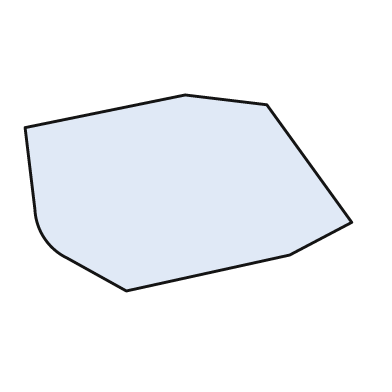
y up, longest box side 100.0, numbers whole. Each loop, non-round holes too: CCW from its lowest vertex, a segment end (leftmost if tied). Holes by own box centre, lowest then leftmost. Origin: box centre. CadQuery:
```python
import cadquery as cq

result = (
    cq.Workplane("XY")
    .moveTo(-19.0, -30.0)
    .lineTo(31.0, -19.0)
    .lineTo(50.0, -9.0)
    .lineTo(24.0, 27.0)
    .lineTo(-1.0, 30.0)
    .lineTo(-50.0, 20.0)
    .lineTo(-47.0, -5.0)
    .threePointArc((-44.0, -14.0), (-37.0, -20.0))
    .close()
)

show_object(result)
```